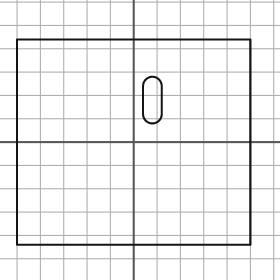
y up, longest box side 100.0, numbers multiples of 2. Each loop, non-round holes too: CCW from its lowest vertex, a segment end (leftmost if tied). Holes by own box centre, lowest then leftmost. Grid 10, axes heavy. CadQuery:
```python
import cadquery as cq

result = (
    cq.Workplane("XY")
    .moveTo(-50.0, -44.0)
    .lineTo(50.0, -44.0)
    .lineTo(50.0, 44.0)
    .lineTo(-50.0, 44.0)
    .close()
    .moveTo(4.0, 12.0)
    .threePointArc((8.0, 8.0), (12.0, 12.0))
    .lineTo(12.0, 24.0)
    .threePointArc((8.0, 28.0), (4.0, 24.0))
    .close()
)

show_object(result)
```